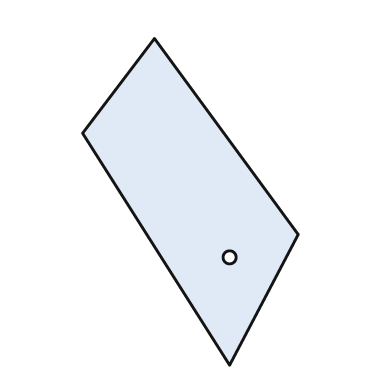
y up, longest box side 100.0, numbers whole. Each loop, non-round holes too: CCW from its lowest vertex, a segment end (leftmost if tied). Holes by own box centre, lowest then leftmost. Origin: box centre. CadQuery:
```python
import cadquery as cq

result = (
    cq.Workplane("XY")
    .moveTo(12.0, -50.0)
    .lineTo(33.0, -10.0)
    .lineTo(-11.0, 50.0)
    .lineTo(-33.0, 21.0)
    .close()
    .moveTo(12.0, -17.0)
    .circle(2.0)
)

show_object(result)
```